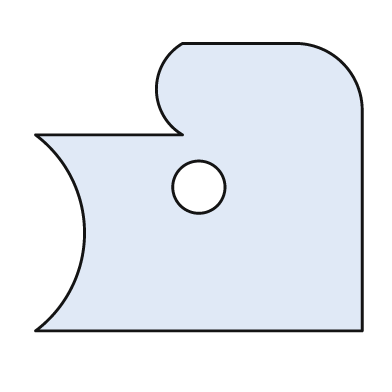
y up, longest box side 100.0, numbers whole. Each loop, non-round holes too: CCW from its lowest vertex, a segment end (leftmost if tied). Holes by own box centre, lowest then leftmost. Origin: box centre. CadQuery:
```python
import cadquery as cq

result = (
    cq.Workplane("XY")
    .moveTo(-50.0, -44.0)
    .lineTo(50.0, -44.0)
    .lineTo(50.0, 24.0)
    .threePointArc((44.0, 38.0), (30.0, 44.0))
    .lineTo(-5.0, 44.0)
    .threePointArc((-13.0, 30.0), (-5.0, 16.0))
    .lineTo(-50.0, 16.0)
    .threePointArc((-35.0, -14.0), (-50.0, -44.0))
    .close()
    .moveTo(0.0, 0.0)
    .circle(8.0)
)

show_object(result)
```